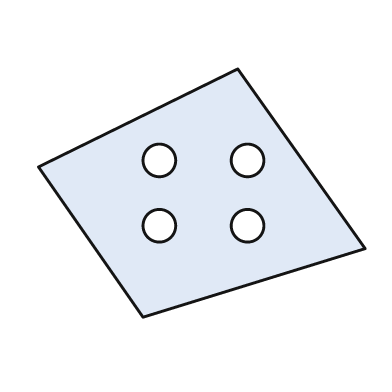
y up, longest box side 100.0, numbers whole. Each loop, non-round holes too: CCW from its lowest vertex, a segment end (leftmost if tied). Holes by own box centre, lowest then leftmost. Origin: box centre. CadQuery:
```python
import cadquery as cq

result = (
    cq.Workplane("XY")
    .moveTo(-18.0, -38.0)
    .lineTo(50.0, -17.0)
    .lineTo(11.0, 38.0)
    .lineTo(-50.0, 8.0)
    .close()
    .moveTo(-13.0, -10.0)
    .circle(5.0)
    .moveTo(14.0, -10.0)
    .circle(5.0)
    .moveTo(-13.0, 10.0)
    .circle(5.0)
    .moveTo(14.0, 10.0)
    .circle(5.0)
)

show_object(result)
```